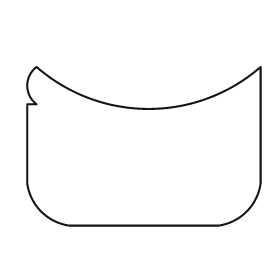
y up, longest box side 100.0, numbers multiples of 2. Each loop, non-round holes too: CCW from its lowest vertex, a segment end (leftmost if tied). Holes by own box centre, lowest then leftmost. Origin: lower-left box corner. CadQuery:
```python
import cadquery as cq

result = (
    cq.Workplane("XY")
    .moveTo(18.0, 0.0)
    .lineTo(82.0, 0.0)
    .threePointArc((94.0, 6.0), (100.0, 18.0))
    .lineTo(100.0, 68.0)
    .threePointArc((52.0, 50.0), (4.0, 68.0))
    .threePointArc((0.0, 60.0), (4.0, 52.0))
    .lineTo(0.0, 52.0)
    .lineTo(0.0, 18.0)
    .threePointArc((6.0, 6.0), (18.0, 0.0))
    .close()
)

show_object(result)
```